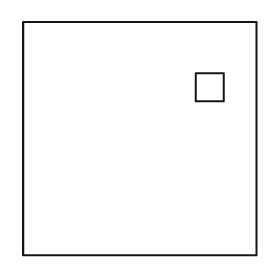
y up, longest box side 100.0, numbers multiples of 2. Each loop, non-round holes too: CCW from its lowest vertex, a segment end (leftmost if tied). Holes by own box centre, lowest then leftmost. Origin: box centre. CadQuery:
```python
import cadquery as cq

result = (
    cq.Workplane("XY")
    .moveTo(-50.0, -50.0)
    .lineTo(50.0, -50.0)
    .lineTo(50.0, 50.0)
    .lineTo(-50.0, 50.0)
    .close()
    .moveTo(24.0, 16.0)
    .lineTo(36.0, 16.0)
    .lineTo(36.0, 28.0)
    .lineTo(24.0, 28.0)
    .close()
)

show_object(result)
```